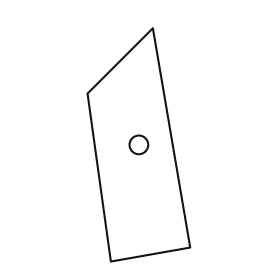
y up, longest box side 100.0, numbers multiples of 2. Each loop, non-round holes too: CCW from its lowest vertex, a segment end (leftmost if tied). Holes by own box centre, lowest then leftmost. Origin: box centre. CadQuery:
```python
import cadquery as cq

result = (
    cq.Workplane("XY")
    .moveTo(-12.0, -50.0)
    .lineTo(22.0, -44.0)
    .lineTo(6.0, 50.0)
    .lineTo(-22.0, 22.0)
    .close()
    .moveTo(0.0, 0.0)
    .circle(4.0)
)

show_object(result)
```